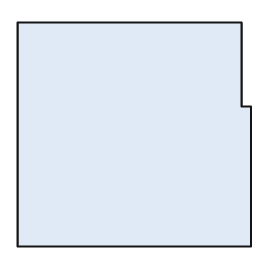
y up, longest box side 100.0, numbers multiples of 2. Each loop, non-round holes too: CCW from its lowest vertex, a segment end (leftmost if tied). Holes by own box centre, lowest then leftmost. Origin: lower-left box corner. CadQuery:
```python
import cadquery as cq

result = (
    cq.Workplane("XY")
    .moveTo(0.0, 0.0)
    .lineTo(100.0, 0.0)
    .lineTo(100.0, 60.0)
    .lineTo(96.0, 60.0)
    .lineTo(96.0, 96.0)
    .lineTo(0.0, 96.0)
    .close()
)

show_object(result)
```